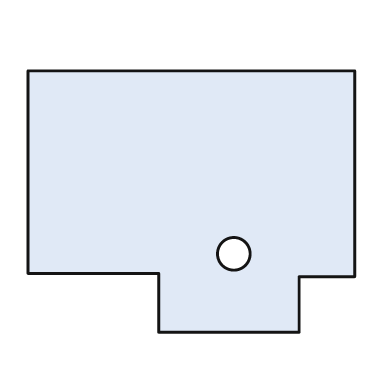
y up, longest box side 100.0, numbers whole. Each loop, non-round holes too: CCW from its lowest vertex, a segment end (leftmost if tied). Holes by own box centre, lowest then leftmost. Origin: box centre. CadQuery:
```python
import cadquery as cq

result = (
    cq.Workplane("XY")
    .moveTo(-10.0, -40.0)
    .lineTo(33.0, -40.0)
    .lineTo(33.0, -23.0)
    .lineTo(50.0, -23.0)
    .lineTo(50.0, 40.0)
    .lineTo(-50.0, 40.0)
    .lineTo(-50.0, -22.0)
    .lineTo(-10.0, -22.0)
    .close()
    .moveTo(13.0, -16.0)
    .circle(5.0)
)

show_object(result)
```